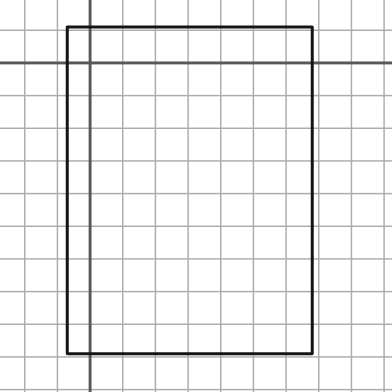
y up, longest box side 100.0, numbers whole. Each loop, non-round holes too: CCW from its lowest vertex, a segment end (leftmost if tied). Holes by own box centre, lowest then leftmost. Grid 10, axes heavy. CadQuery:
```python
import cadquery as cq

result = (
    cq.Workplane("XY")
    .moveTo(-7.0, -89.0)
    .lineTo(68.0, -89.0)
    .lineTo(68.0, 11.0)
    .lineTo(-7.0, 11.0)
    .close()
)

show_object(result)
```